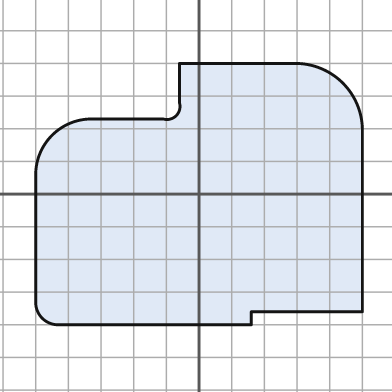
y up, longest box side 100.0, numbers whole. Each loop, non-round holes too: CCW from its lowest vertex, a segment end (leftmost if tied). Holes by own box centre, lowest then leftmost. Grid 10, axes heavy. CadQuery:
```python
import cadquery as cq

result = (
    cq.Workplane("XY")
    .moveTo(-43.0, -40.0)
    .lineTo(16.0, -40.0)
    .lineTo(16.0, -36.0)
    .lineTo(50.0, -36.0)
    .lineTo(50.0, 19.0)
    .threePointArc((44.0, 34.0), (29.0, 40.0))
    .lineTo(-6.0, 40.0)
    .lineTo(-6.0, 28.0)
    .threePointArc((-7.0, 24.0), (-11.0, 23.0))
    .lineTo(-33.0, 23.0)
    .threePointArc((-45.0, 18.0), (-50.0, 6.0))
    .lineTo(-50.0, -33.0)
    .threePointArc((-48.0, -38.0), (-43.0, -40.0))
    .close()
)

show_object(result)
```